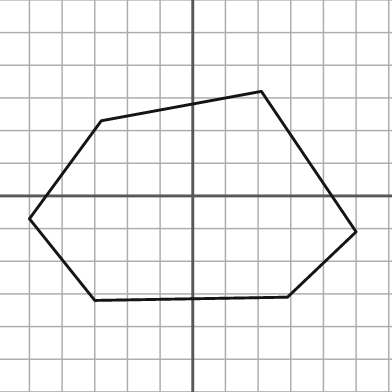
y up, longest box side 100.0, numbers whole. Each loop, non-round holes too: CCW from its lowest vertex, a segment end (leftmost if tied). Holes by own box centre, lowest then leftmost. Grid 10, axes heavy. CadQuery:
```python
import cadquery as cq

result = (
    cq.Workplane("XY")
    .moveTo(-30.0, -32.0)
    .lineTo(29.0, -31.0)
    .lineTo(50.0, -11.0)
    .lineTo(21.0, 32.0)
    .lineTo(-28.0, 23.0)
    .lineTo(-50.0, -7.0)
    .close()
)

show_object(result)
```